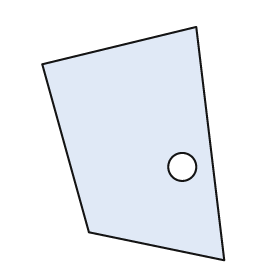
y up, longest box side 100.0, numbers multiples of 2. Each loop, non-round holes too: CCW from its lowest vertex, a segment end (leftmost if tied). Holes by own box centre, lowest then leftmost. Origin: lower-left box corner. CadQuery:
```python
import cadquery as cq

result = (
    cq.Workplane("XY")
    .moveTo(78.0, 0.0)
    .lineTo(66.0, 100.0)
    .lineTo(0.0, 84.0)
    .lineTo(20.0, 12.0)
    .close()
    .moveTo(60.0, 40.0)
    .circle(6.0)
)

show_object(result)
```